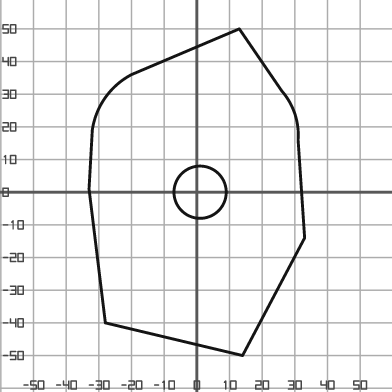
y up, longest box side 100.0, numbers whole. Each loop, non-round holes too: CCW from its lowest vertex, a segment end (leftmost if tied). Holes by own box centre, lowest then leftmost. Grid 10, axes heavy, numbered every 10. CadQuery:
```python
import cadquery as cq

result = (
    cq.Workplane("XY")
    .moveTo(14.0, -50.0)
    .lineTo(33.0, -14.0)
    .lineTo(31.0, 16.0)
    .threePointArc((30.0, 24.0), (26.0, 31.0))
    .lineTo(13.0, 50.0)
    .lineTo(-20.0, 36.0)
    .threePointArc((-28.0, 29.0), (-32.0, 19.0))
    .lineTo(-33.0, 1.0)
    .lineTo(-28.0, -40.0)
    .close()
    .moveTo(1.0, 0.0)
    .circle(8.0)
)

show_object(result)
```